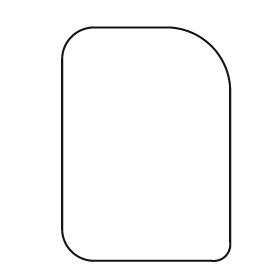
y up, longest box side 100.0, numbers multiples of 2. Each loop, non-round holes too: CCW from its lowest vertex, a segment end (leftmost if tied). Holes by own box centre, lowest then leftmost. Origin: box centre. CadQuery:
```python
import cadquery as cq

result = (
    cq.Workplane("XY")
    .moveTo(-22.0, -50.0)
    .lineTo(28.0, -50.0)
    .threePointArc((34.0, -48.0), (36.0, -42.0))
    .lineTo(36.0, 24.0)
    .threePointArc((28.0, 42.0), (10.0, 50.0))
    .lineTo(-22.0, 50.0)
    .threePointArc((-32.0, 46.0), (-36.0, 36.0))
    .lineTo(-36.0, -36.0)
    .threePointArc((-32.0, -46.0), (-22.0, -50.0))
    .close()
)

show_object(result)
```